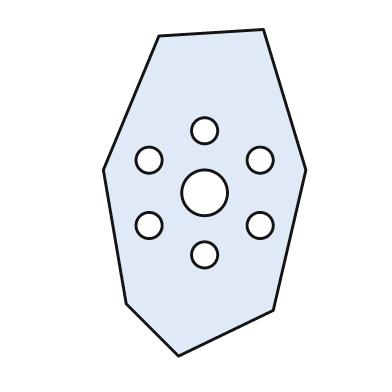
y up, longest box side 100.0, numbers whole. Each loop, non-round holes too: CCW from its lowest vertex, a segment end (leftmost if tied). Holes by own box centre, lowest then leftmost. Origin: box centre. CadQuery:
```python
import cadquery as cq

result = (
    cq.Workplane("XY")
    .moveTo(-8.0, -50.0)
    .lineTo(21.0, -36.0)
    .lineTo(31.0, 7.0)
    .lineTo(18.0, 50.0)
    .lineTo(-14.0, 48.0)
    .lineTo(-31.0, 7.0)
    .lineTo(-24.0, -34.0)
    .close()
    .moveTo(0.0, -19.0)
    .circle(4.0)
    .moveTo(-17.0, -10.0)
    .circle(4.0)
    .moveTo(17.0, -10.0)
    .circle(4.0)
    .moveTo(0.0, 0.0)
    .circle(7.0)
    .moveTo(-17.0, 10.0)
    .circle(4.0)
    .moveTo(17.0, 10.0)
    .circle(4.0)
    .moveTo(0.0, 19.0)
    .circle(4.0)
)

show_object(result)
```